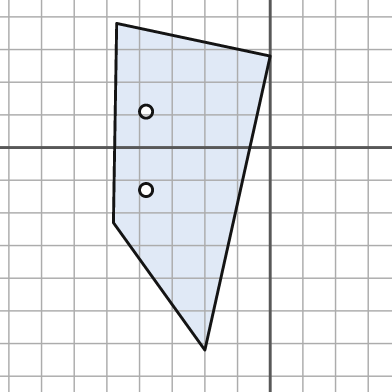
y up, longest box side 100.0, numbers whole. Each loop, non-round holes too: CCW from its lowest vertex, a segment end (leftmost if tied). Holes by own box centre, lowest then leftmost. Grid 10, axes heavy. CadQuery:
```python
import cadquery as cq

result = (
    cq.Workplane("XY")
    .moveTo(-20.0, -62.0)
    .lineTo(0.0, 28.0)
    .lineTo(-47.0, 38.0)
    .lineTo(-48.0, -23.0)
    .close()
    .moveTo(-38.0, -13.0)
    .circle(2.0)
    .moveTo(-38.0, 11.0)
    .circle(2.0)
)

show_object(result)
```